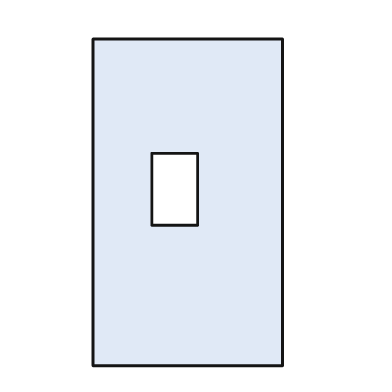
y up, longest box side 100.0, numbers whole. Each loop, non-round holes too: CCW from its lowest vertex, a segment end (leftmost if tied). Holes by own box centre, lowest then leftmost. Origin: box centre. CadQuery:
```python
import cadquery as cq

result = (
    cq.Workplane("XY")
    .moveTo(-29.0, -50.0)
    .lineTo(29.0, -50.0)
    .lineTo(29.0, 50.0)
    .lineTo(-29.0, 50.0)
    .close()
    .moveTo(-11.0, -7.0)
    .lineTo(3.0, -7.0)
    .lineTo(3.0, 15.0)
    .lineTo(-11.0, 15.0)
    .close()
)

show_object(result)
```